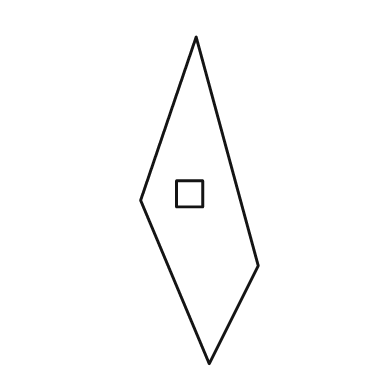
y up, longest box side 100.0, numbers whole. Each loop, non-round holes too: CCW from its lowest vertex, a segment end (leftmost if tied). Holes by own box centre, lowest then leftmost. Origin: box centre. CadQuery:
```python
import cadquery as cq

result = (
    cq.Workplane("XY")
    .moveTo(3.0, -50.0)
    .lineTo(18.0, -20.0)
    .lineTo(-1.0, 50.0)
    .lineTo(-18.0, 0.0)
    .close()
    .moveTo(-7.0, -2.0)
    .lineTo(1.0, -2.0)
    .lineTo(1.0, 6.0)
    .lineTo(-7.0, 6.0)
    .close()
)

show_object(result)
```